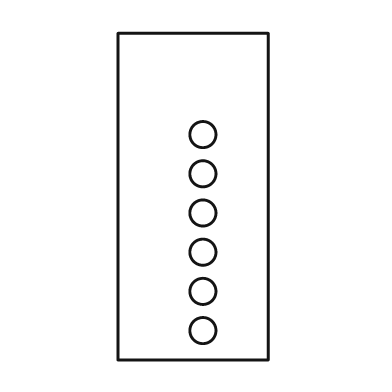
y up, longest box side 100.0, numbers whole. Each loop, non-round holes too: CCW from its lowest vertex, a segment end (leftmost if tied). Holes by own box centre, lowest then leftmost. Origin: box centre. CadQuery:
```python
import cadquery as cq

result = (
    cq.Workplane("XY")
    .moveTo(-23.0, -50.0)
    .lineTo(23.0, -50.0)
    .lineTo(23.0, 50.0)
    .lineTo(-23.0, 50.0)
    .close()
    .moveTo(3.0, -41.0)
    .circle(4.0)
    .moveTo(3.0, -29.0)
    .circle(4.0)
    .moveTo(3.0, -17.0)
    .circle(4.0)
    .moveTo(3.0, -5.0)
    .circle(4.0)
    .moveTo(3.0, 7.0)
    .circle(4.0)
    .moveTo(3.0, 19.0)
    .circle(4.0)
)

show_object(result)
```